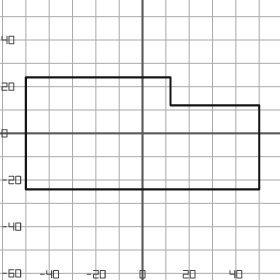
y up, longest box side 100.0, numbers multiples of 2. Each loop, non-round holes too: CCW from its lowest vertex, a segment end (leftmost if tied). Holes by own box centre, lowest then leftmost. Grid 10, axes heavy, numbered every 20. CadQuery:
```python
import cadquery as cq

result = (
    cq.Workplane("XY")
    .moveTo(-50.0, -24.0)
    .lineTo(50.0, -24.0)
    .lineTo(50.0, 12.0)
    .lineTo(12.0, 12.0)
    .lineTo(12.0, 24.0)
    .lineTo(-50.0, 24.0)
    .close()
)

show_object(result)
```